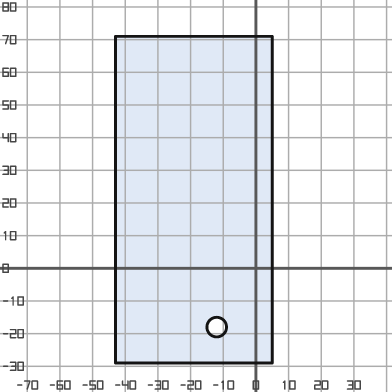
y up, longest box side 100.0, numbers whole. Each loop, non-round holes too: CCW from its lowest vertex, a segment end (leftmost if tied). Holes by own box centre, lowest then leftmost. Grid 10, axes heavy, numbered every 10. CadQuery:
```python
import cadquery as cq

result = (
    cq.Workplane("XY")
    .moveTo(-43.0, -29.0)
    .lineTo(5.0, -29.0)
    .lineTo(5.0, 71.0)
    .lineTo(-43.0, 71.0)
    .close()
    .moveTo(-12.0, -18.0)
    .circle(3.0)
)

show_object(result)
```